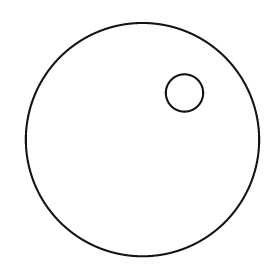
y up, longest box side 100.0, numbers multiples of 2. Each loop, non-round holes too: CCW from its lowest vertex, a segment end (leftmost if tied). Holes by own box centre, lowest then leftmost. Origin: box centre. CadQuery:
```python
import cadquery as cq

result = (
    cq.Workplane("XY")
    .moveTo(0.0, 0.0)
    .circle(50.0)
    .moveTo(18.0, 20.0)
    .circle(8.0)
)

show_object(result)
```